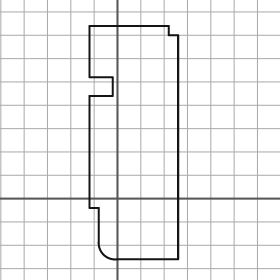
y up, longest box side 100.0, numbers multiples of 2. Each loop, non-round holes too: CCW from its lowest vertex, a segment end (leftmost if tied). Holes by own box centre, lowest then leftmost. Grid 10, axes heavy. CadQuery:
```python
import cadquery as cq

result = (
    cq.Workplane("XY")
    .moveTo(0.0, -26.0)
    .lineTo(26.0, -26.0)
    .lineTo(26.0, 70.0)
    .lineTo(22.0, 70.0)
    .lineTo(22.0, 74.0)
    .lineTo(-12.0, 74.0)
    .lineTo(-12.0, 52.0)
    .lineTo(-2.0, 52.0)
    .lineTo(-2.0, 44.0)
    .lineTo(-12.0, 44.0)
    .lineTo(-12.0, -4.0)
    .lineTo(-8.0, -4.0)
    .lineTo(-8.0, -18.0)
    .threePointArc((-6.0, -24.0), (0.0, -26.0))
    .close()
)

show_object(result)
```